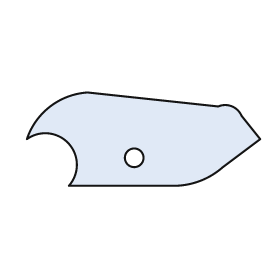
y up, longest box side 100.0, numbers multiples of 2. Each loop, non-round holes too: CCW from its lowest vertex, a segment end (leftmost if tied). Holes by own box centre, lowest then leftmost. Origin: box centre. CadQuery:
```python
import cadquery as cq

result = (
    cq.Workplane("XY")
    .moveTo(-32.0, -20.0)
    .lineTo(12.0, -20.0)
    .threePointArc((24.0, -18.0), (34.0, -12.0))
    .lineTo(50.0, 0.0)
    .lineTo(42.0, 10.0)
    .threePointArc((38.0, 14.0), (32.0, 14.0))
    .lineTo(-24.0, 20.0)
    .threePointArc((-40.0, 14.0), (-50.0, 0.0))
    .threePointArc((-32.0, -2.0), (-32.0, -20.0))
    .close()
    .moveTo(-4.0, -8.0)
    .circle(4.0)
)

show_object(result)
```